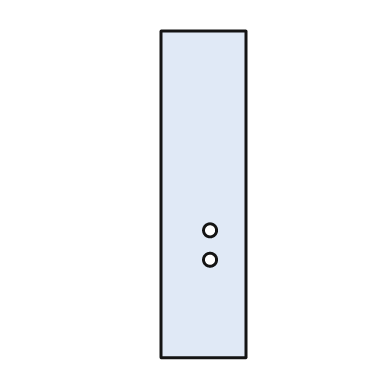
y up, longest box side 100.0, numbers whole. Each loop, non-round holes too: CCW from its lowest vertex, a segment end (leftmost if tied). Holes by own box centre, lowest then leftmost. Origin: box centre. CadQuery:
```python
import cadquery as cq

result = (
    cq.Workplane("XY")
    .moveTo(-13.0, -50.0)
    .lineTo(13.0, -50.0)
    .lineTo(13.0, 50.0)
    .lineTo(-13.0, 50.0)
    .close()
    .moveTo(2.0, -20.0)
    .circle(2.0)
    .moveTo(2.0, -11.0)
    .circle(2.0)
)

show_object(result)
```